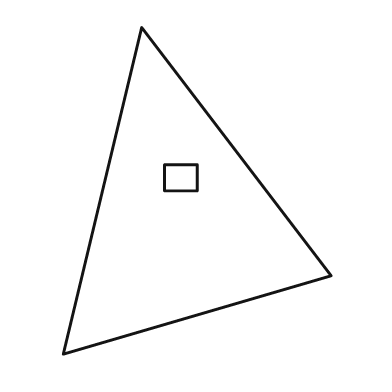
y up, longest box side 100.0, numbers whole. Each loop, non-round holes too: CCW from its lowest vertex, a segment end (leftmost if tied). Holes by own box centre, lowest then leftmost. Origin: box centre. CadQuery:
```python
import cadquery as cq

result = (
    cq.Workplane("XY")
    .moveTo(-41.0, -50.0)
    .lineTo(41.0, -26.0)
    .lineTo(-17.0, 50.0)
    .close()
    .moveTo(-10.0, 0.0)
    .lineTo(0.0, 0.0)
    .lineTo(0.0, 8.0)
    .lineTo(-10.0, 8.0)
    .close()
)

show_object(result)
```